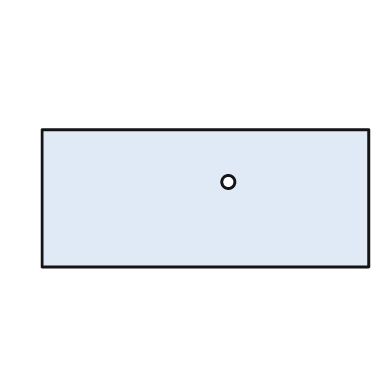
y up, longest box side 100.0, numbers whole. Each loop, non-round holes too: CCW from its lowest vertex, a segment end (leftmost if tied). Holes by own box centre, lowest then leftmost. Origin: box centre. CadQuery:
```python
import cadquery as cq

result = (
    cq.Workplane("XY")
    .moveTo(-50.0, -21.0)
    .lineTo(50.0, -21.0)
    .lineTo(50.0, 21.0)
    .lineTo(-50.0, 21.0)
    .close()
    .moveTo(7.0, 5.0)
    .circle(2.0)
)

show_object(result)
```